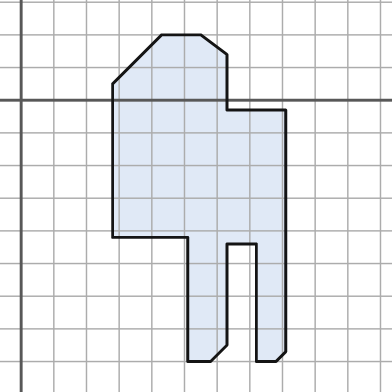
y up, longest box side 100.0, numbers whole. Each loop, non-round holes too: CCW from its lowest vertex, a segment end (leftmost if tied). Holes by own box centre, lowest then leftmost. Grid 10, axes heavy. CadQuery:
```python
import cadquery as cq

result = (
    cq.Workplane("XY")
    .moveTo(51.0, -80.0)
    .lineTo(58.0, -80.0)
    .lineTo(63.0, -75.0)
    .lineTo(63.0, -44.0)
    .lineTo(72.0, -44.0)
    .lineTo(72.0, -80.0)
    .lineTo(78.0, -80.0)
    .lineTo(81.0, -77.0)
    .lineTo(81.0, -3.0)
    .lineTo(63.0, -3.0)
    .lineTo(63.0, 14.0)
    .lineTo(55.0, 20.0)
    .lineTo(43.0, 20.0)
    .lineTo(28.0, 5.0)
    .lineTo(28.0, -42.0)
    .lineTo(51.0, -42.0)
    .close()
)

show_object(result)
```